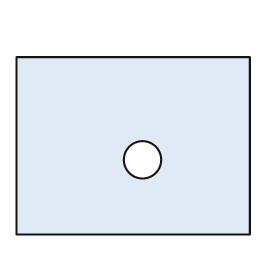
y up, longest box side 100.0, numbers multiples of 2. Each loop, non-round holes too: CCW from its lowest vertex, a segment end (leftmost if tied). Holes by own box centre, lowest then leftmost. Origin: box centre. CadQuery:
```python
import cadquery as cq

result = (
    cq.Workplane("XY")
    .moveTo(-50.0, -38.0)
    .lineTo(50.0, -38.0)
    .lineTo(50.0, 38.0)
    .lineTo(-50.0, 38.0)
    .close()
    .moveTo(4.0, -6.0)
    .circle(8.0)
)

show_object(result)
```